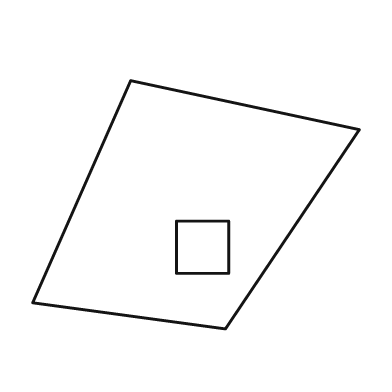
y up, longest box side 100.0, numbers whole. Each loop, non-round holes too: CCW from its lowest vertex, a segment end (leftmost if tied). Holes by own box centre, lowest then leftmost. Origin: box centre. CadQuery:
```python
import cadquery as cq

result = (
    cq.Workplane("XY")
    .moveTo(9.0, -38.0)
    .lineTo(50.0, 23.0)
    .lineTo(-20.0, 38.0)
    .lineTo(-50.0, -30.0)
    .close()
    .moveTo(-6.0, -21.0)
    .lineTo(10.0, -21.0)
    .lineTo(10.0, -5.0)
    .lineTo(-6.0, -5.0)
    .close()
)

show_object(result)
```